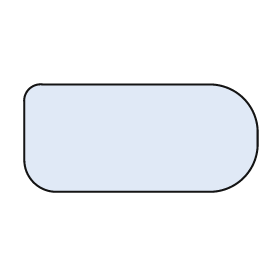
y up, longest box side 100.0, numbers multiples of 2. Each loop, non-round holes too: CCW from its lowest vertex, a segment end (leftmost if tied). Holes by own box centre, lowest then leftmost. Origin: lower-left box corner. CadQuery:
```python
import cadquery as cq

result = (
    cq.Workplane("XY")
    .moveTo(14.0, 0.0)
    .lineTo(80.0, 0.0)
    .threePointArc((94.0, 6.0), (100.0, 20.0))
    .lineTo(100.0, 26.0)
    .threePointArc((94.0, 40.0), (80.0, 46.0))
    .lineTo(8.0, 46.0)
    .threePointArc((2.0, 44.0), (0.0, 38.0))
    .lineTo(0.0, 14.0)
    .threePointArc((4.0, 4.0), (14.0, 0.0))
    .close()
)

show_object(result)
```